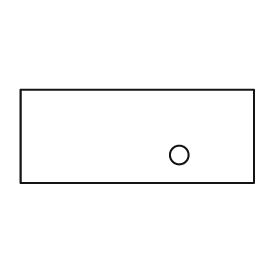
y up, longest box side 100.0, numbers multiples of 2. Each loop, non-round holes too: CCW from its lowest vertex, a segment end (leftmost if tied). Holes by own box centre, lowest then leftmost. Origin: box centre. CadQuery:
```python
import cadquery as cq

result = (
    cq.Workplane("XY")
    .moveTo(-50.0, -20.0)
    .lineTo(50.0, -20.0)
    .lineTo(50.0, 20.0)
    .lineTo(-50.0, 20.0)
    .close()
    .moveTo(18.0, -8.0)
    .circle(4.0)
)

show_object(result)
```